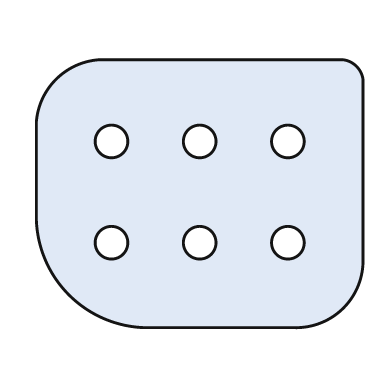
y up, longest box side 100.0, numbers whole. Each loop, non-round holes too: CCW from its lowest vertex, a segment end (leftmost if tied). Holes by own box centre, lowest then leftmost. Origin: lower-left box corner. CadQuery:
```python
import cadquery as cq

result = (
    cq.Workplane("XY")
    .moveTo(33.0, 0.0)
    .lineTo(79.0, 0.0)
    .threePointArc((94.0, 6.0), (100.0, 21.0))
    .lineTo(100.0, 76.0)
    .threePointArc((98.0, 80.0), (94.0, 82.0))
    .lineTo(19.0, 82.0)
    .threePointArc((6.0, 76.0), (0.0, 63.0))
    .lineTo(0.0, 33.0)
    .threePointArc((10.0, 10.0), (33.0, 0.0))
    .close()
    .moveTo(23.0, 26.0)
    .circle(5.0)
    .moveTo(50.0, 26.0)
    .circle(5.0)
    .moveTo(77.0, 26.0)
    .circle(5.0)
    .moveTo(23.0, 57.0)
    .circle(5.0)
    .moveTo(50.0, 57.0)
    .circle(5.0)
    .moveTo(77.0, 57.0)
    .circle(5.0)
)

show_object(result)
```